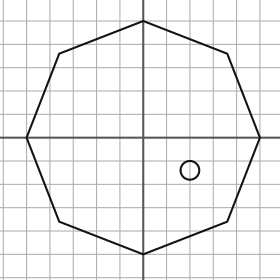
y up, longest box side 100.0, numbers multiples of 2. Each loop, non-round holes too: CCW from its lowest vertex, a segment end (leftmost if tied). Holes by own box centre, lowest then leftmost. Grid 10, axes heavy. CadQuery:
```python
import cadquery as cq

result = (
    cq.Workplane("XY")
    .moveTo(0.0, -50.0)
    .lineTo(36.0, -36.0)
    .lineTo(50.0, 0.0)
    .lineTo(36.0, 36.0)
    .lineTo(0.0, 50.0)
    .lineTo(-36.0, 36.0)
    .lineTo(-50.0, 0.0)
    .lineTo(-36.0, -36.0)
    .close()
    .moveTo(20.0, -14.0)
    .circle(4.0)
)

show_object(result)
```